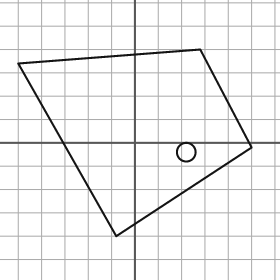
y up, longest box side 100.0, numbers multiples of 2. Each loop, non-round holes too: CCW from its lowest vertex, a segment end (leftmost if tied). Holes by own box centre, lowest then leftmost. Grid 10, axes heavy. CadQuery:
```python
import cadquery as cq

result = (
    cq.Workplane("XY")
    .moveTo(-8.0, -40.0)
    .lineTo(50.0, -2.0)
    .lineTo(28.0, 40.0)
    .lineTo(-50.0, 34.0)
    .close()
    .moveTo(22.0, -4.0)
    .circle(4.0)
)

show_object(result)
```